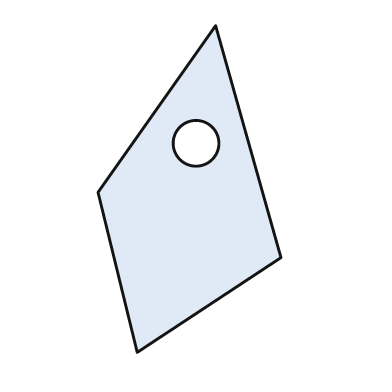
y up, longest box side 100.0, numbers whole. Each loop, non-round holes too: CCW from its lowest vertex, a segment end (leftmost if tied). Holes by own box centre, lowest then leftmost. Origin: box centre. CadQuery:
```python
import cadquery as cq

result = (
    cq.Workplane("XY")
    .moveTo(-16.0, -50.0)
    .lineTo(28.0, -21.0)
    .lineTo(8.0, 50.0)
    .lineTo(-28.0, -1.0)
    .close()
    .moveTo(2.0, 14.0)
    .circle(7.0)
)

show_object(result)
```